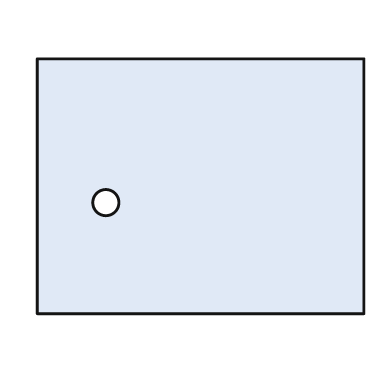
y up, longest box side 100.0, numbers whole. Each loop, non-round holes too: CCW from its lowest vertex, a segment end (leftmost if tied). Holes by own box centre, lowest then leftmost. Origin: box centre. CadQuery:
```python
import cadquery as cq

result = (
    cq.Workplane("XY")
    .moveTo(-50.0, -39.0)
    .lineTo(50.0, -39.0)
    .lineTo(50.0, 39.0)
    .lineTo(-50.0, 39.0)
    .close()
    .moveTo(-29.0, -5.0)
    .circle(4.0)
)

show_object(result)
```